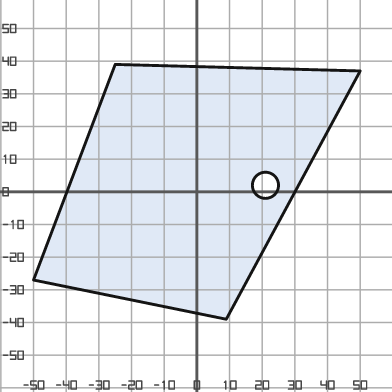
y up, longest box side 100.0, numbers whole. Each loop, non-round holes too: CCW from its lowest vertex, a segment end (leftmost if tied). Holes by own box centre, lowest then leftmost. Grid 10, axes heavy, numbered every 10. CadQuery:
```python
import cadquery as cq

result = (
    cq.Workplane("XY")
    .moveTo(9.0, -39.0)
    .lineTo(50.0, 37.0)
    .lineTo(-25.0, 39.0)
    .lineTo(-50.0, -27.0)
    .close()
    .moveTo(21.0, 2.0)
    .circle(4.0)
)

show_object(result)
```